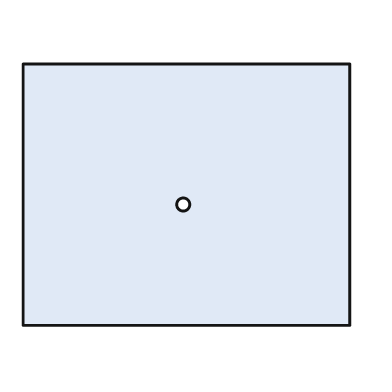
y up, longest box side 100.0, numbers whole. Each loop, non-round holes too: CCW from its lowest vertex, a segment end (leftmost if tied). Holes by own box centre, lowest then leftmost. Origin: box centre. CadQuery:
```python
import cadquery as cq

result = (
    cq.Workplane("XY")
    .moveTo(-50.0, -40.0)
    .lineTo(50.0, -40.0)
    .lineTo(50.0, 40.0)
    .lineTo(-50.0, 40.0)
    .close()
    .moveTo(-1.0, -3.0)
    .circle(2.0)
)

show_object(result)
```